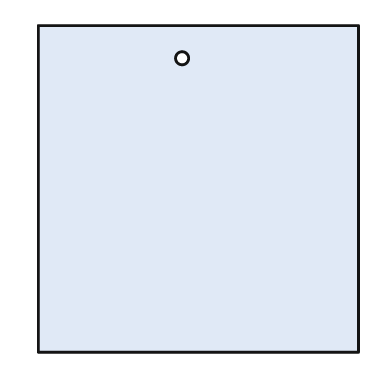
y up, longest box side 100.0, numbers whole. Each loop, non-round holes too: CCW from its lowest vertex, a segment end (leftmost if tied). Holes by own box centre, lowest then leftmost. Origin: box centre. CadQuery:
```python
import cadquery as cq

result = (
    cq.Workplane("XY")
    .moveTo(-49.0, -50.0)
    .lineTo(49.0, -50.0)
    .lineTo(49.0, 50.0)
    .lineTo(-49.0, 50.0)
    .close()
    .moveTo(-5.0, 40.0)
    .circle(2.0)
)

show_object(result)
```